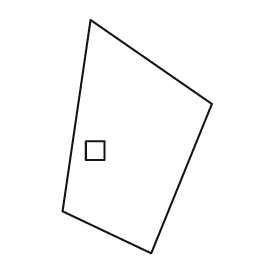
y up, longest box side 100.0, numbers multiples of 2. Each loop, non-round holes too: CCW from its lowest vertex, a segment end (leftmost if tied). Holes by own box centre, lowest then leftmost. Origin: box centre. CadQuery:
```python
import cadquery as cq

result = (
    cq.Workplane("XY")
    .moveTo(6.0, -50.0)
    .lineTo(32.0, 14.0)
    .lineTo(-20.0, 50.0)
    .lineTo(-32.0, -32.0)
    .close()
    .moveTo(-22.0, -10.0)
    .lineTo(-14.0, -10.0)
    .lineTo(-14.0, -2.0)
    .lineTo(-22.0, -2.0)
    .close()
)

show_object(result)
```